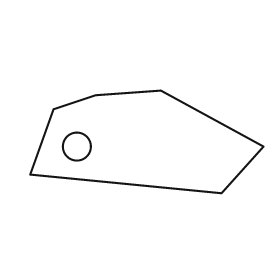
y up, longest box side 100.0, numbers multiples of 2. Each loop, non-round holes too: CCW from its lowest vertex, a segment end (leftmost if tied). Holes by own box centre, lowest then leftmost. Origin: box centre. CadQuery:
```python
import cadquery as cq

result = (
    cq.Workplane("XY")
    .moveTo(32.0, -22.0)
    .lineTo(50.0, -2.0)
    .lineTo(6.0, 22.0)
    .lineTo(-22.0, 20.0)
    .lineTo(-40.0, 14.0)
    .lineTo(-50.0, -14.0)
    .close()
    .moveTo(-30.0, -2.0)
    .circle(6.0)
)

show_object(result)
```